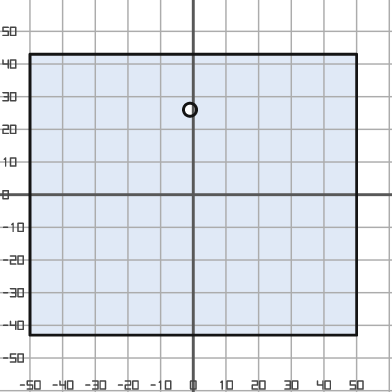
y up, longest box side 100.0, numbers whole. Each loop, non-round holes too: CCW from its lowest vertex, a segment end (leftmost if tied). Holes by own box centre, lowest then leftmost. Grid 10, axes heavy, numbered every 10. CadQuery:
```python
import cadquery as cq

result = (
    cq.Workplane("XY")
    .moveTo(-50.0, -43.0)
    .lineTo(50.0, -43.0)
    .lineTo(50.0, 43.0)
    .lineTo(-50.0, 43.0)
    .close()
    .moveTo(-1.0, 26.0)
    .circle(2.0)
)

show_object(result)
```